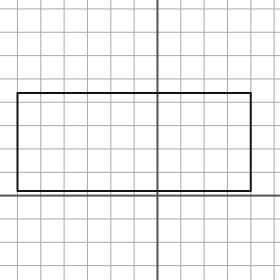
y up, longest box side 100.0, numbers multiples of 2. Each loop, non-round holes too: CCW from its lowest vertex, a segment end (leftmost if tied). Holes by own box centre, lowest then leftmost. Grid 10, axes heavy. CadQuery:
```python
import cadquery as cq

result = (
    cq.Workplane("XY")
    .moveTo(-60.0, 2.0)
    .lineTo(40.0, 2.0)
    .lineTo(40.0, 44.0)
    .lineTo(-60.0, 44.0)
    .close()
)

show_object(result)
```